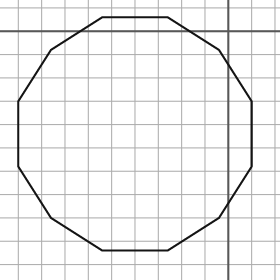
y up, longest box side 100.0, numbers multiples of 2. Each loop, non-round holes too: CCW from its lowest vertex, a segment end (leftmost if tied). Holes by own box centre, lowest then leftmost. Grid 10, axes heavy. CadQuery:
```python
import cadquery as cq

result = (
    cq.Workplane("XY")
    .moveTo(-54.0, -94.0)
    .lineTo(-26.0, -94.0)
    .lineTo(-4.0, -80.0)
    .lineTo(10.0, -58.0)
    .lineTo(10.0, -30.0)
    .lineTo(-4.0, -8.0)
    .lineTo(-26.0, 6.0)
    .lineTo(-54.0, 6.0)
    .lineTo(-76.0, -8.0)
    .lineTo(-90.0, -30.0)
    .lineTo(-90.0, -58.0)
    .lineTo(-76.0, -80.0)
    .close()
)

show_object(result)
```